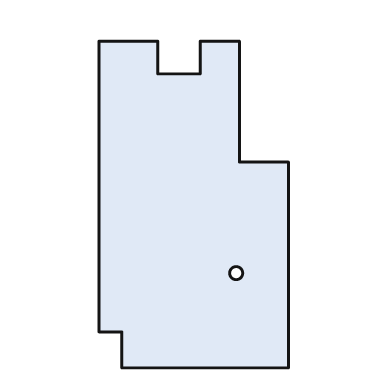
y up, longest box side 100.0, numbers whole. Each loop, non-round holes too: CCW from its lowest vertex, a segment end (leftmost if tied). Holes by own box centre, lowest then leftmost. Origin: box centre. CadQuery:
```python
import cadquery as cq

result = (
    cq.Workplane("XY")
    .moveTo(-22.0, -50.0)
    .lineTo(29.0, -50.0)
    .lineTo(29.0, 13.0)
    .lineTo(14.0, 13.0)
    .lineTo(14.0, 50.0)
    .lineTo(2.0, 50.0)
    .lineTo(2.0, 40.0)
    .lineTo(-11.0, 40.0)
    .lineTo(-11.0, 50.0)
    .lineTo(-29.0, 50.0)
    .lineTo(-29.0, -39.0)
    .lineTo(-22.0, -39.0)
    .close()
    .moveTo(13.0, -21.0)
    .circle(2.0)
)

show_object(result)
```